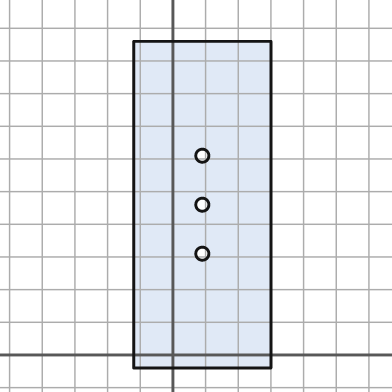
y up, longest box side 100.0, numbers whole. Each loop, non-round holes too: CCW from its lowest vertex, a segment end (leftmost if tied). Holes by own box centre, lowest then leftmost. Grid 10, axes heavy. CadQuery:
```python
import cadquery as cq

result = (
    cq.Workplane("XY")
    .moveTo(-12.0, -4.0)
    .lineTo(30.0, -4.0)
    .lineTo(30.0, 96.0)
    .lineTo(-12.0, 96.0)
    .close()
    .moveTo(9.0, 31.0)
    .circle(2.0)
    .moveTo(9.0, 46.0)
    .circle(2.0)
    .moveTo(9.0, 61.0)
    .circle(2.0)
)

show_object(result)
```